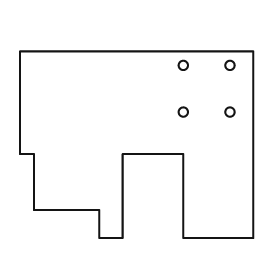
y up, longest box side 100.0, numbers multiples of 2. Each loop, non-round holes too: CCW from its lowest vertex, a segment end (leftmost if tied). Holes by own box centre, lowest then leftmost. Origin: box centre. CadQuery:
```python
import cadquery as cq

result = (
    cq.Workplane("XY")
    .moveTo(-16.0, -40.0)
    .lineTo(-6.0, -40.0)
    .lineTo(-6.0, -4.0)
    .lineTo(20.0, -4.0)
    .lineTo(20.0, -40.0)
    .lineTo(50.0, -40.0)
    .lineTo(50.0, 40.0)
    .lineTo(-50.0, 40.0)
    .lineTo(-50.0, -4.0)
    .lineTo(-44.0, -4.0)
    .lineTo(-44.0, -28.0)
    .lineTo(-16.0, -28.0)
    .close()
    .moveTo(20.0, 14.0)
    .circle(2.0)
    .moveTo(40.0, 14.0)
    .circle(2.0)
    .moveTo(20.0, 34.0)
    .circle(2.0)
    .moveTo(40.0, 34.0)
    .circle(2.0)
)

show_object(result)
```